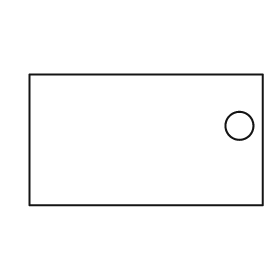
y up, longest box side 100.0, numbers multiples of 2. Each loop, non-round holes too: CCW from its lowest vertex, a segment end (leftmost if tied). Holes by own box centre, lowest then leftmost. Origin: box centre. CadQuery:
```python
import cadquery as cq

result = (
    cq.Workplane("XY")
    .moveTo(-50.0, -28.0)
    .lineTo(50.0, -28.0)
    .lineTo(50.0, 28.0)
    .lineTo(-50.0, 28.0)
    .close()
    .moveTo(40.0, 6.0)
    .circle(6.0)
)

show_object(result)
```